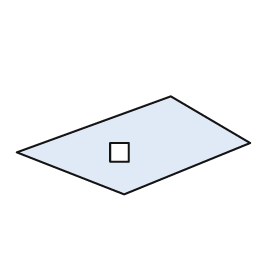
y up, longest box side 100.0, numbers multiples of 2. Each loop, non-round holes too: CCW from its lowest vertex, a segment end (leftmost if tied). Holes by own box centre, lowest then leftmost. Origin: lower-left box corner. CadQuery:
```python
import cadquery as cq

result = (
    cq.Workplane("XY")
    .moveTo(46.0, 0.0)
    .lineTo(100.0, 22.0)
    .lineTo(66.0, 42.0)
    .lineTo(0.0, 18.0)
    .close()
    .moveTo(40.0, 14.0)
    .lineTo(48.0, 14.0)
    .lineTo(48.0, 22.0)
    .lineTo(40.0, 22.0)
    .close()
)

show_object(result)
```